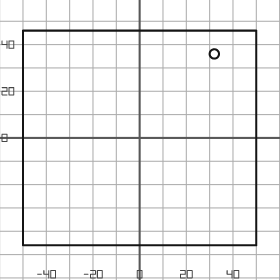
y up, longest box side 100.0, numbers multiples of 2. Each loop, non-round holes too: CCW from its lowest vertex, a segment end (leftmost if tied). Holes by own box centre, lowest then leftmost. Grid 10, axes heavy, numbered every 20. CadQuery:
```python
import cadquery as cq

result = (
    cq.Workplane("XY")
    .moveTo(-50.0, -46.0)
    .lineTo(50.0, -46.0)
    .lineTo(50.0, 46.0)
    .lineTo(-50.0, 46.0)
    .close()
    .moveTo(32.0, 36.0)
    .circle(2.0)
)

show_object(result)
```